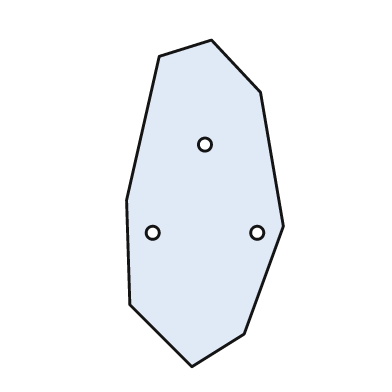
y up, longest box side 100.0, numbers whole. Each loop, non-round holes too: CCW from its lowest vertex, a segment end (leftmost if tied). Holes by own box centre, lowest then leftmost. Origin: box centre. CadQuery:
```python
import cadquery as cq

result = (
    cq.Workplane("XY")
    .moveTo(-4.0, -50.0)
    .lineTo(12.0, -40.0)
    .lineTo(24.0, -7.0)
    .lineTo(17.0, 34.0)
    .lineTo(2.0, 50.0)
    .lineTo(-14.0, 45.0)
    .lineTo(-24.0, 1.0)
    .lineTo(-23.0, -31.0)
    .close()
    .moveTo(-16.0, -9.0)
    .circle(2.0)
    .moveTo(16.0, -9.0)
    .circle(2.0)
    .moveTo(0.0, 18.0)
    .circle(2.0)
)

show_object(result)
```